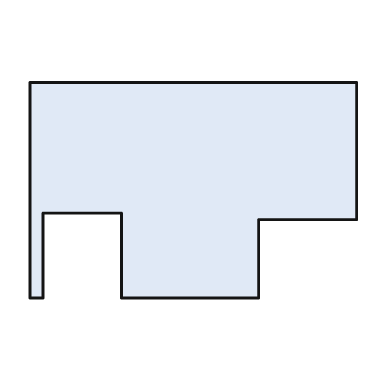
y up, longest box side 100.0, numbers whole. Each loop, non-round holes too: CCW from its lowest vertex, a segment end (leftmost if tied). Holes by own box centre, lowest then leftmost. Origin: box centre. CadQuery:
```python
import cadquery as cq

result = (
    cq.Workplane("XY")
    .moveTo(-50.0, -33.0)
    .lineTo(-46.0, -33.0)
    .lineTo(-46.0, -7.0)
    .lineTo(-22.0, -7.0)
    .lineTo(-22.0, -33.0)
    .lineTo(20.0, -33.0)
    .lineTo(20.0, -9.0)
    .lineTo(50.0, -9.0)
    .lineTo(50.0, 33.0)
    .lineTo(-50.0, 33.0)
    .close()
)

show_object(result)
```